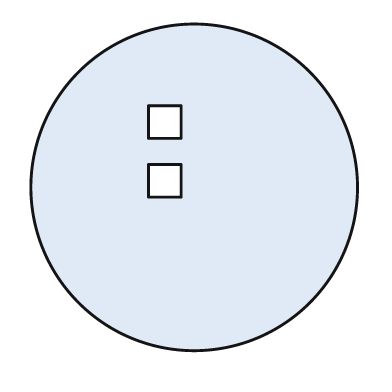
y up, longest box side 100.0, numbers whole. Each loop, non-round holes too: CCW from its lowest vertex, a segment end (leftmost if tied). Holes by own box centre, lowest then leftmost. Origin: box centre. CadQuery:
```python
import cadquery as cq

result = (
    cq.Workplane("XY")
    .moveTo(0.0, 0.0)
    .circle(50.0)
    .moveTo(-14.0, -3.0)
    .lineTo(-4.0, -3.0)
    .lineTo(-4.0, 7.0)
    .lineTo(-14.0, 7.0)
    .close()
    .moveTo(-14.0, 15.0)
    .lineTo(-4.0, 15.0)
    .lineTo(-4.0, 25.0)
    .lineTo(-14.0, 25.0)
    .close()
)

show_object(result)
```